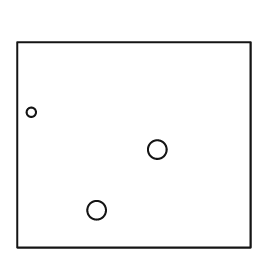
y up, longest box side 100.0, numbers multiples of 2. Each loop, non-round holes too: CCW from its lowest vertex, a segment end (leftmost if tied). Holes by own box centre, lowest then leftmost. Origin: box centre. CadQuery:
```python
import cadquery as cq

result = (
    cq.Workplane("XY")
    .moveTo(-50.0, -44.0)
    .lineTo(50.0, -44.0)
    .lineTo(50.0, 44.0)
    .lineTo(-50.0, 44.0)
    .close()
    .moveTo(-16.0, -28.0)
    .circle(4.0)
    .moveTo(10.0, -2.0)
    .circle(4.0)
    .moveTo(-44.0, 14.0)
    .circle(2.0)
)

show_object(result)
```